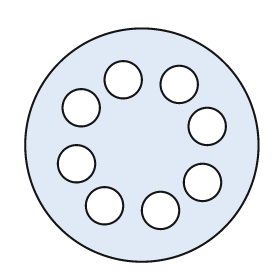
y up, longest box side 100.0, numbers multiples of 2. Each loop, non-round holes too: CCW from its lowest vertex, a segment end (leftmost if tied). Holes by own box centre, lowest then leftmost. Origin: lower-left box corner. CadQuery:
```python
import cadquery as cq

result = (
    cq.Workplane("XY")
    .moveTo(50.0, 50.0)
    .circle(50.0)
    .moveTo(58.0, 22.0)
    .circle(8.0)
    .moveTo(34.0, 24.0)
    .circle(8.0)
    .moveTo(76.0, 34.0)
    .circle(8.0)
    .moveTo(22.0, 42.0)
    .circle(8.0)
    .moveTo(78.0, 58.0)
    .circle(8.0)
    .moveTo(24.0, 66.0)
    .circle(8.0)
    .moveTo(66.0, 76.0)
    .circle(8.0)
    .moveTo(42.0, 78.0)
    .circle(8.0)
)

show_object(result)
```